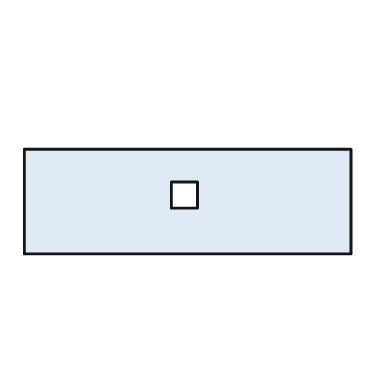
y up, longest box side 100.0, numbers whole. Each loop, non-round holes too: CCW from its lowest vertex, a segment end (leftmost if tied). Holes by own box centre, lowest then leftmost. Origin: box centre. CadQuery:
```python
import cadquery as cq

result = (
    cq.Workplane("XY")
    .moveTo(-50.0, -16.0)
    .lineTo(50.0, -16.0)
    .lineTo(50.0, 16.0)
    .lineTo(-50.0, 16.0)
    .close()
    .moveTo(-5.0, -2.0)
    .lineTo(3.0, -2.0)
    .lineTo(3.0, 6.0)
    .lineTo(-5.0, 6.0)
    .close()
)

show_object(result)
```